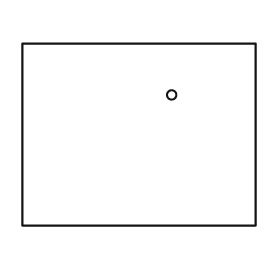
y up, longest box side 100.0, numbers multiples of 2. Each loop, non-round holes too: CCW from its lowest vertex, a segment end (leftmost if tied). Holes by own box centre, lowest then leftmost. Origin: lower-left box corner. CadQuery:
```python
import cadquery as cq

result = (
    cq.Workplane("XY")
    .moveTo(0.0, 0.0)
    .lineTo(100.0, 0.0)
    .lineTo(100.0, 78.0)
    .lineTo(0.0, 78.0)
    .close()
    .moveTo(64.0, 56.0)
    .circle(2.0)
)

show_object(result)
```